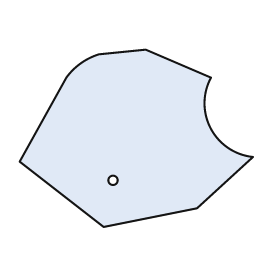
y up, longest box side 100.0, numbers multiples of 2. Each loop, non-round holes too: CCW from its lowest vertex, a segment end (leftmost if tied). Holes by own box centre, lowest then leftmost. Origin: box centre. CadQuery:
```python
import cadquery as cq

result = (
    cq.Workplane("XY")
    .moveTo(-14.0, -38.0)
    .lineTo(26.0, -30.0)
    .lineTo(50.0, -8.0)
    .threePointArc((32.0, 4.0), (32.0, 26.0))
    .lineTo(4.0, 38.0)
    .lineTo(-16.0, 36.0)
    .threePointArc((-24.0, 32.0), (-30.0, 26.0))
    .lineTo(-50.0, -10.0)
    .close()
    .moveTo(-10.0, -18.0)
    .circle(2.0)
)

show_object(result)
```